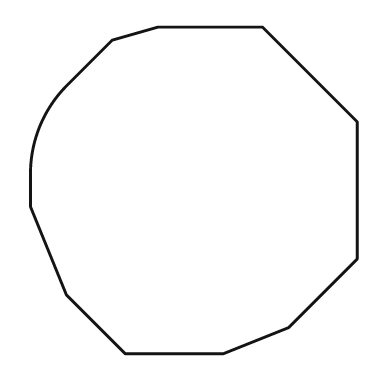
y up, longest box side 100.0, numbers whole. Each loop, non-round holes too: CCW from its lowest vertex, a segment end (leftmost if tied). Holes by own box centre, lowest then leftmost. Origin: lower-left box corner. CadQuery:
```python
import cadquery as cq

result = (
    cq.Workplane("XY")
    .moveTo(29.0, 0.0)
    .lineTo(59.0, 0.0)
    .lineTo(79.0, 8.0)
    .lineTo(100.0, 29.0)
    .lineTo(100.0, 71.0)
    .lineTo(71.0, 100.0)
    .lineTo(39.0, 100.0)
    .lineTo(25.0, 96.0)
    .lineTo(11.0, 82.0)
    .threePointArc((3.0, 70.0), (0.0, 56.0))
    .lineTo(0.0, 45.0)
    .lineTo(11.0, 18.0)
    .close()
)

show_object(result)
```